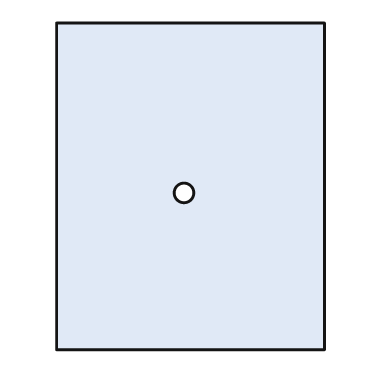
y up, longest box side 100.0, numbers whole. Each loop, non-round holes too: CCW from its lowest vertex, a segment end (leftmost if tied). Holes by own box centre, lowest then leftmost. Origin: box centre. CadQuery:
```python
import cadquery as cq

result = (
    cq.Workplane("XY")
    .moveTo(-41.0, -50.0)
    .lineTo(41.0, -50.0)
    .lineTo(41.0, 50.0)
    .lineTo(-41.0, 50.0)
    .close()
    .moveTo(-2.0, -2.0)
    .circle(3.0)
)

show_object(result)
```